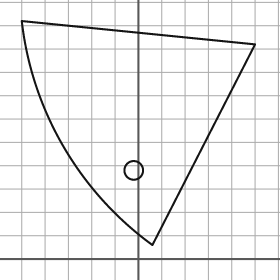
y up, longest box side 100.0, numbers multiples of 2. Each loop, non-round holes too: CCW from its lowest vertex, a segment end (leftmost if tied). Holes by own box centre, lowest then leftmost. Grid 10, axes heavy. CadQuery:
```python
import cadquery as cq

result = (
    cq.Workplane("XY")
    .moveTo(6.0, 6.0)
    .lineTo(50.0, 92.0)
    .lineTo(-50.0, 102.0)
    .threePointArc((-32.0, 48.0), (6.0, 6.0))
    .close()
    .moveTo(-2.0, 38.0)
    .circle(4.0)
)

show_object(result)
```